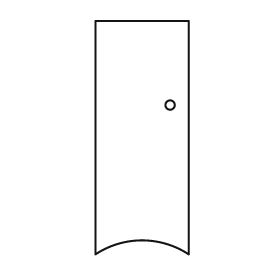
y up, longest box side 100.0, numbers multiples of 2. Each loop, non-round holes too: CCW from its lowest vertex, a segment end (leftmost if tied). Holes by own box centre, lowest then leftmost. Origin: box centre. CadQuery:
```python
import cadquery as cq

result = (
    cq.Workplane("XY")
    .moveTo(-20.0, -50.0)
    .threePointArc((0.0, -44.0), (20.0, -50.0))
    .lineTo(20.0, 50.0)
    .lineTo(-20.0, 50.0)
    .close()
    .moveTo(12.0, 14.0)
    .circle(2.0)
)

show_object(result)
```